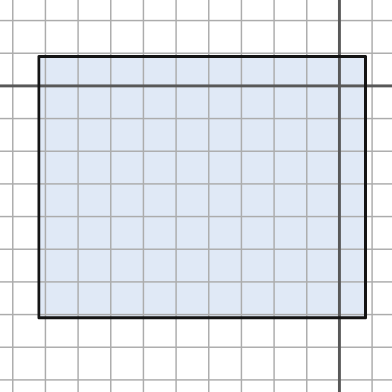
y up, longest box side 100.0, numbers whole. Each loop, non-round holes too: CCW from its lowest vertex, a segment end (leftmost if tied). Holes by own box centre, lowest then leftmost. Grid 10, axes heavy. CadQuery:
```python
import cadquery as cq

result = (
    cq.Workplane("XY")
    .moveTo(-92.0, -71.0)
    .lineTo(8.0, -71.0)
    .lineTo(8.0, 9.0)
    .lineTo(-92.0, 9.0)
    .close()
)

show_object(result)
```